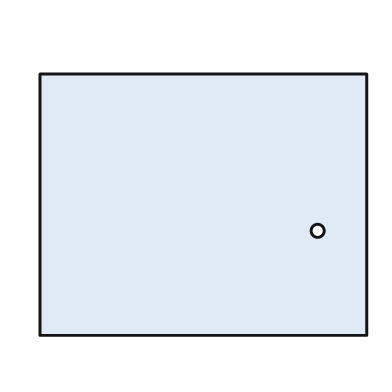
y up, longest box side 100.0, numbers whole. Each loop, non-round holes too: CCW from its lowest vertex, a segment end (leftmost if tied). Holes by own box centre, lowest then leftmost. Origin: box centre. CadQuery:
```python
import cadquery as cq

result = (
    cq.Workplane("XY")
    .moveTo(-50.0, -40.0)
    .lineTo(50.0, -40.0)
    .lineTo(50.0, 40.0)
    .lineTo(-50.0, 40.0)
    .close()
    .moveTo(35.0, -8.0)
    .circle(2.0)
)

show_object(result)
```